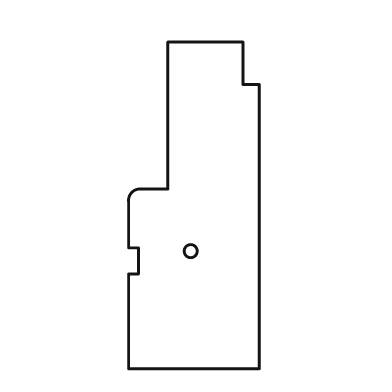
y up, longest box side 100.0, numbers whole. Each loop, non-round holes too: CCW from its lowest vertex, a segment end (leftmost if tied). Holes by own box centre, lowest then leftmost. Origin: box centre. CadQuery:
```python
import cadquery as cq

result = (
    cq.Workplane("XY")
    .moveTo(-20.0, -50.0)
    .lineTo(20.0, -50.0)
    .lineTo(20.0, 37.0)
    .lineTo(15.0, 37.0)
    .lineTo(15.0, 50.0)
    .lineTo(-8.0, 50.0)
    .lineTo(-8.0, 5.0)
    .lineTo(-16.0, 5.0)
    .threePointArc((-19.0, 4.0), (-20.0, 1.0))
    .lineTo(-20.0, -13.0)
    .lineTo(-17.0, -13.0)
    .lineTo(-17.0, -21.0)
    .lineTo(-20.0, -21.0)
    .close()
    .moveTo(-1.0, -14.0)
    .circle(2.0)
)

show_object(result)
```